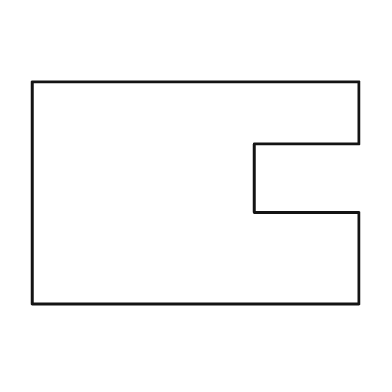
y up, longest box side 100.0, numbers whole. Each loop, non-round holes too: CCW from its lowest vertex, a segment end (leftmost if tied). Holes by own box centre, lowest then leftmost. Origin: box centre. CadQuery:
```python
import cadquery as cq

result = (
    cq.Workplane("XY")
    .moveTo(-50.0, -34.0)
    .lineTo(50.0, -34.0)
    .lineTo(50.0, -6.0)
    .lineTo(18.0, -6.0)
    .lineTo(18.0, 15.0)
    .lineTo(50.0, 15.0)
    .lineTo(50.0, 34.0)
    .lineTo(-50.0, 34.0)
    .close()
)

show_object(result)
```